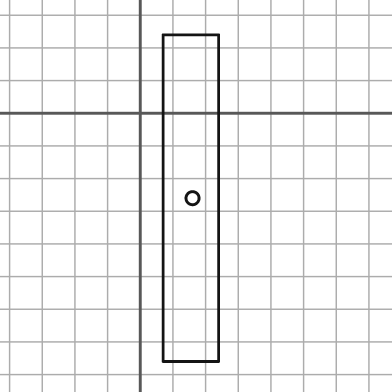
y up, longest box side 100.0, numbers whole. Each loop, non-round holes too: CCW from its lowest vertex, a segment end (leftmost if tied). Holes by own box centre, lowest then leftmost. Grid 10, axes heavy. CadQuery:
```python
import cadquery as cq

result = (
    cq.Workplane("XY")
    .moveTo(7.0, -76.0)
    .lineTo(24.0, -76.0)
    .lineTo(24.0, 24.0)
    .lineTo(7.0, 24.0)
    .close()
    .moveTo(16.0, -26.0)
    .circle(2.0)
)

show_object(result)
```